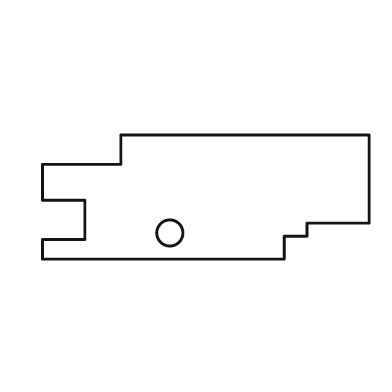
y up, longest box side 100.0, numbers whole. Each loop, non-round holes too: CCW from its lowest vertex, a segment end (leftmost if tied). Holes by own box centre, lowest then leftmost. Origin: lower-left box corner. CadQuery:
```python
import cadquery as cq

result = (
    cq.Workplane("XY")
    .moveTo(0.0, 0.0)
    .lineTo(74.0, 0.0)
    .lineTo(74.0, 7.0)
    .lineTo(81.0, 7.0)
    .lineTo(81.0, 11.0)
    .lineTo(100.0, 11.0)
    .lineTo(100.0, 38.0)
    .lineTo(24.0, 38.0)
    .lineTo(24.0, 29.0)
    .lineTo(0.0, 29.0)
    .lineTo(0.0, 18.0)
    .lineTo(13.0, 18.0)
    .lineTo(13.0, 6.0)
    .lineTo(0.0, 6.0)
    .close()
    .moveTo(39.0, 8.0)
    .circle(4.0)
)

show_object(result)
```